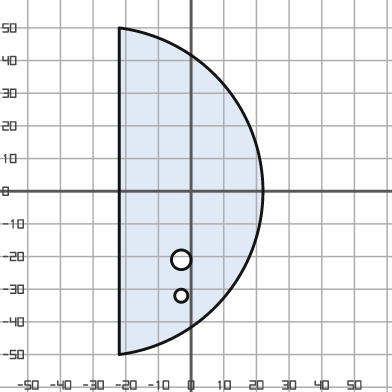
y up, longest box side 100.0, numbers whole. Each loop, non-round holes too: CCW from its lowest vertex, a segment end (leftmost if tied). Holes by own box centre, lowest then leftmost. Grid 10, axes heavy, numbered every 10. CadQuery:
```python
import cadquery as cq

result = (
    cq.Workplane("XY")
    .moveTo(-22.0, -50.0)
    .threePointArc((22.0, 0.0), (-22.0, 50.0))
    .close()
    .moveTo(-3.0, -32.0)
    .circle(2.0)
    .moveTo(-3.0, -21.0)
    .circle(3.0)
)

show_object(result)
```